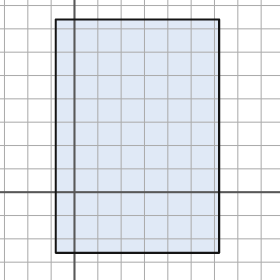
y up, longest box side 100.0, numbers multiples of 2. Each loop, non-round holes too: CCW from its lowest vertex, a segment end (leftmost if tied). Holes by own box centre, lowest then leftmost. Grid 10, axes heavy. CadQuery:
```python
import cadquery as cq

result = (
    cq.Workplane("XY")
    .moveTo(-8.0, -26.0)
    .lineTo(62.0, -26.0)
    .lineTo(62.0, 74.0)
    .lineTo(-8.0, 74.0)
    .close()
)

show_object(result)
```